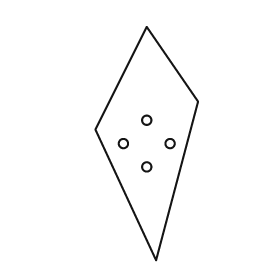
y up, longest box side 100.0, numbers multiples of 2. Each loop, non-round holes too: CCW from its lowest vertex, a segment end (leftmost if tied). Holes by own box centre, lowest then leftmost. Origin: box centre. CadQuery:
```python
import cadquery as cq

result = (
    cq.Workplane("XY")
    .moveTo(4.0, -50.0)
    .lineTo(22.0, 18.0)
    .lineTo(0.0, 50.0)
    .lineTo(-22.0, 6.0)
    .close()
    .moveTo(0.0, -10.0)
    .circle(2.0)
    .moveTo(-10.0, 0.0)
    .circle(2.0)
    .moveTo(10.0, 0.0)
    .circle(2.0)
    .moveTo(0.0, 10.0)
    .circle(2.0)
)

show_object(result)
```